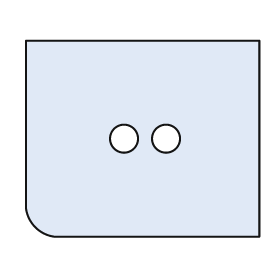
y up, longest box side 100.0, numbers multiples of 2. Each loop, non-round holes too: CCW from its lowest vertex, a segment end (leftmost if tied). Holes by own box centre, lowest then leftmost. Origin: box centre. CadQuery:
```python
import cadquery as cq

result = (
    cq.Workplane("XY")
    .moveTo(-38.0, -42.0)
    .lineTo(50.0, -42.0)
    .lineTo(50.0, 42.0)
    .lineTo(-50.0, 42.0)
    .lineTo(-50.0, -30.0)
    .threePointArc((-46.0, -38.0), (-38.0, -42.0))
    .close()
    .moveTo(-8.0, 0.0)
    .circle(6.0)
    .moveTo(10.0, 0.0)
    .circle(6.0)
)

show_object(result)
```